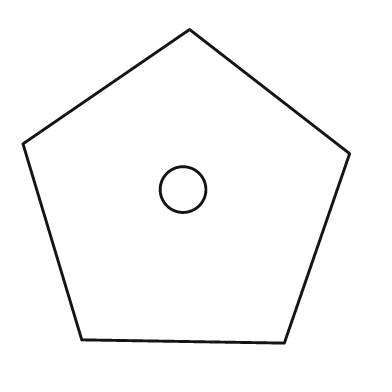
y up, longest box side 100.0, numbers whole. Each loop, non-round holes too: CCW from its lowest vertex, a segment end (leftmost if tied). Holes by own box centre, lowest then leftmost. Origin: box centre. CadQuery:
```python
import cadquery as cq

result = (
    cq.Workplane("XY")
    .moveTo(30.0, -48.0)
    .lineTo(50.0, 10.0)
    .lineTo(1.0, 48.0)
    .lineTo(-50.0, 13.0)
    .lineTo(-32.0, -47.0)
    .close()
    .moveTo(-1.0, -1.0)
    .circle(7.0)
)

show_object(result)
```